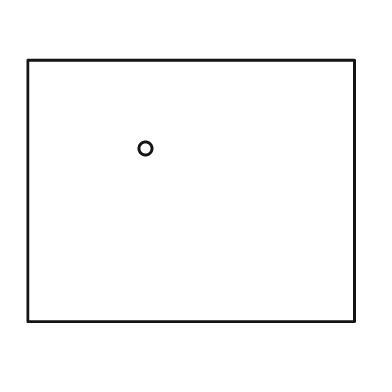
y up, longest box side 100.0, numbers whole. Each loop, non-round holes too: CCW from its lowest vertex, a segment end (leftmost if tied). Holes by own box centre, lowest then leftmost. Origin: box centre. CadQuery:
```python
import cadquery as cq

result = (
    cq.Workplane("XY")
    .moveTo(-50.0, -40.0)
    .lineTo(50.0, -40.0)
    .lineTo(50.0, 40.0)
    .lineTo(-50.0, 40.0)
    .close()
    .moveTo(-14.0, 13.0)
    .circle(2.0)
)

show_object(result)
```